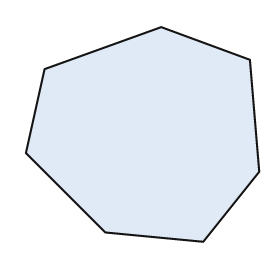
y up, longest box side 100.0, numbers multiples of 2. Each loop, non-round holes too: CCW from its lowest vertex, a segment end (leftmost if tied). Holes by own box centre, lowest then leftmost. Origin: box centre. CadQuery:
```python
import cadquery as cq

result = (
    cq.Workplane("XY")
    .moveTo(26.0, -46.0)
    .lineTo(50.0, -16.0)
    .lineTo(46.0, 32.0)
    .lineTo(8.0, 46.0)
    .lineTo(-42.0, 28.0)
    .lineTo(-50.0, -8.0)
    .lineTo(-16.0, -42.0)
    .close()
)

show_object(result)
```